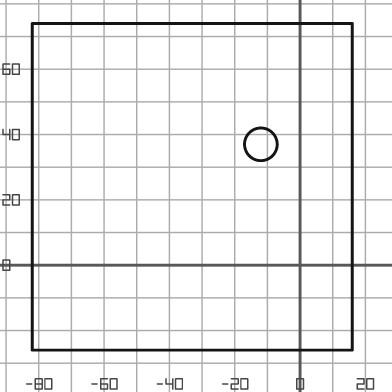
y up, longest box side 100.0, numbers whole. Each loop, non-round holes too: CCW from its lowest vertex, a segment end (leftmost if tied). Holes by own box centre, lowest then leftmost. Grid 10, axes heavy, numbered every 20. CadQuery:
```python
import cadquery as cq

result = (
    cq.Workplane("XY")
    .moveTo(-82.0, -26.0)
    .lineTo(16.0, -26.0)
    .lineTo(16.0, 74.0)
    .lineTo(-82.0, 74.0)
    .close()
    .moveTo(-12.0, 37.0)
    .circle(5.0)
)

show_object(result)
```